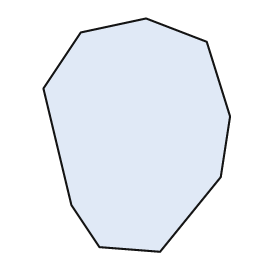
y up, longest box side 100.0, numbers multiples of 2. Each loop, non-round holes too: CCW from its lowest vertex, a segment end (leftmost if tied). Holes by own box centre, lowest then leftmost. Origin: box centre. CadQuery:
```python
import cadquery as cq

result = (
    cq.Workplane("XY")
    .moveTo(10.0, -50.0)
    .lineTo(36.0, -18.0)
    .lineTo(40.0, 8.0)
    .lineTo(30.0, 40.0)
    .lineTo(4.0, 50.0)
    .lineTo(-24.0, 44.0)
    .lineTo(-40.0, 20.0)
    .lineTo(-28.0, -30.0)
    .lineTo(-16.0, -48.0)
    .close()
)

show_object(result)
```